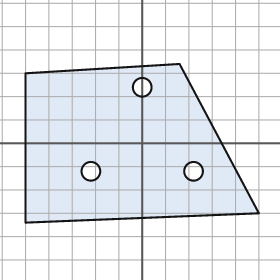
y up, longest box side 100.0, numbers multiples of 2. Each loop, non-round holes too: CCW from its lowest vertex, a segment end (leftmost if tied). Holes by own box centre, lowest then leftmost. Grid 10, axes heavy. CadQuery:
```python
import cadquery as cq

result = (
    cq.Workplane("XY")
    .moveTo(-50.0, -34.0)
    .lineTo(50.0, -30.0)
    .lineTo(16.0, 34.0)
    .lineTo(-50.0, 30.0)
    .close()
    .moveTo(-22.0, -12.0)
    .circle(4.0)
    .moveTo(22.0, -12.0)
    .circle(4.0)
    .moveTo(0.0, 24.0)
    .circle(4.0)
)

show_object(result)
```